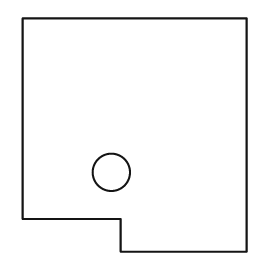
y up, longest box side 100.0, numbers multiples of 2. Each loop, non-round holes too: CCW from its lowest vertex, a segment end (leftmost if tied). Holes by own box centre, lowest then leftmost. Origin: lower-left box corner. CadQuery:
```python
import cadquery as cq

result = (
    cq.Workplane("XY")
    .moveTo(42.0, 0.0)
    .lineTo(96.0, 0.0)
    .lineTo(96.0, 100.0)
    .lineTo(0.0, 100.0)
    .lineTo(0.0, 14.0)
    .lineTo(42.0, 14.0)
    .close()
    .moveTo(38.0, 34.0)
    .circle(8.0)
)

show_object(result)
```